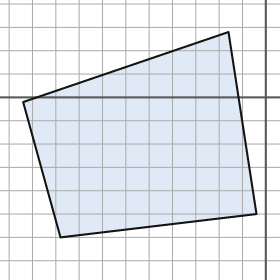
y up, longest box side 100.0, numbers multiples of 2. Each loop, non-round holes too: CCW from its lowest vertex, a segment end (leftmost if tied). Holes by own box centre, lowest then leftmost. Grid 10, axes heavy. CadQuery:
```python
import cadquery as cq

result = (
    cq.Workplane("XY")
    .moveTo(-88.0, -60.0)
    .lineTo(-4.0, -50.0)
    .lineTo(-16.0, 28.0)
    .lineTo(-104.0, -2.0)
    .close()
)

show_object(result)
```